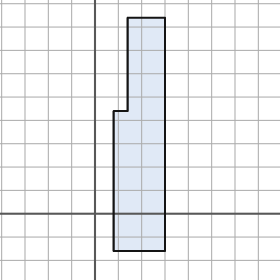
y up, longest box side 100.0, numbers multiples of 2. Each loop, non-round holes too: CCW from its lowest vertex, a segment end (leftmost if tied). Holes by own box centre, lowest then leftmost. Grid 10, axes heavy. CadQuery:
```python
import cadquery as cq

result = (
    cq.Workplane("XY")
    .moveTo(8.0, -16.0)
    .lineTo(30.0, -16.0)
    .lineTo(30.0, 84.0)
    .lineTo(14.0, 84.0)
    .lineTo(14.0, 44.0)
    .lineTo(8.0, 44.0)
    .close()
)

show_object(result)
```